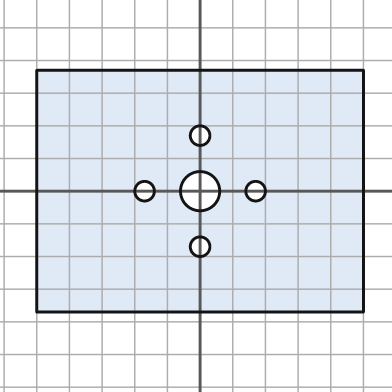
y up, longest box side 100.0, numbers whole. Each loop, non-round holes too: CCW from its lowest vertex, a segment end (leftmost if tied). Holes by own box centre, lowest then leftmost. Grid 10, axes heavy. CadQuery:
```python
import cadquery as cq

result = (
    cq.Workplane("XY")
    .moveTo(-50.0, -37.0)
    .lineTo(50.0, -37.0)
    .lineTo(50.0, 37.0)
    .lineTo(-50.0, 37.0)
    .close()
    .moveTo(0.0, -17.0)
    .circle(3.0)
    .moveTo(-17.0, 0.0)
    .circle(3.0)
    .moveTo(0.0, 0.0)
    .circle(6.0)
    .moveTo(17.0, 0.0)
    .circle(3.0)
    .moveTo(0.0, 17.0)
    .circle(3.0)
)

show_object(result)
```